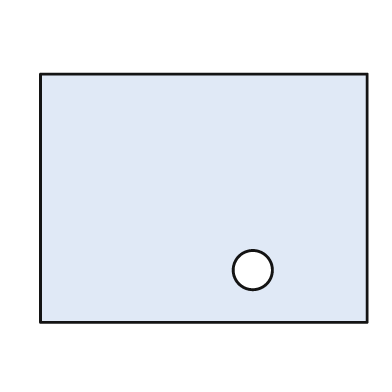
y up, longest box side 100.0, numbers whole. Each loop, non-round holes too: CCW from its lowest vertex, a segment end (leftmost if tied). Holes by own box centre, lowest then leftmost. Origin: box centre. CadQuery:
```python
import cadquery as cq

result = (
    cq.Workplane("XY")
    .moveTo(-50.0, -38.0)
    .lineTo(50.0, -38.0)
    .lineTo(50.0, 38.0)
    .lineTo(-50.0, 38.0)
    .close()
    .moveTo(15.0, -22.0)
    .circle(6.0)
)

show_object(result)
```